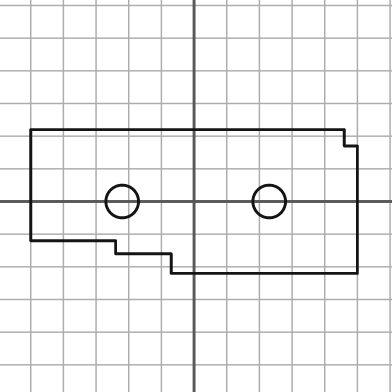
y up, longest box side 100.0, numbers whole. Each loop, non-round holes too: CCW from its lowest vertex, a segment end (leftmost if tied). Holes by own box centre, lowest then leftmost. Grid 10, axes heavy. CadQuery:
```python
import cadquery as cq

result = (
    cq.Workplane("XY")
    .moveTo(-7.0, -22.0)
    .lineTo(50.0, -22.0)
    .lineTo(50.0, 17.0)
    .lineTo(46.0, 17.0)
    .lineTo(46.0, 22.0)
    .lineTo(-50.0, 22.0)
    .lineTo(-50.0, -12.0)
    .lineTo(-24.0, -12.0)
    .lineTo(-24.0, -16.0)
    .lineTo(-7.0, -16.0)
    .close()
    .moveTo(-22.0, 0.0)
    .circle(5.0)
    .moveTo(23.0, 0.0)
    .circle(5.0)
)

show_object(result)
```